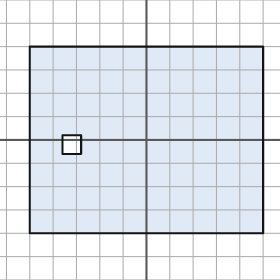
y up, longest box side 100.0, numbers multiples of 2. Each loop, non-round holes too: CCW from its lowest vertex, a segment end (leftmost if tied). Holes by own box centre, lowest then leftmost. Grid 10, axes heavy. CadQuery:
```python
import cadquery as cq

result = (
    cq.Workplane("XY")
    .moveTo(-50.0, -40.0)
    .lineTo(50.0, -40.0)
    .lineTo(50.0, 40.0)
    .lineTo(-50.0, 40.0)
    .close()
    .moveTo(-36.0, -6.0)
    .lineTo(-28.0, -6.0)
    .lineTo(-28.0, 2.0)
    .lineTo(-36.0, 2.0)
    .close()
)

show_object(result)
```